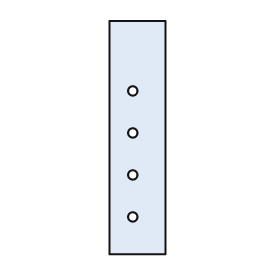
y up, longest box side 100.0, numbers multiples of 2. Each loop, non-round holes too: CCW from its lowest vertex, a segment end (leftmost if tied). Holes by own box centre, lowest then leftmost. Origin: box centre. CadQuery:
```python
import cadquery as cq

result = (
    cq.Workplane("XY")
    .moveTo(-12.0, -50.0)
    .lineTo(12.0, -50.0)
    .lineTo(12.0, 50.0)
    .lineTo(-12.0, 50.0)
    .close()
    .moveTo(-2.0, -34.0)
    .circle(2.0)
    .moveTo(-2.0, -16.0)
    .circle(2.0)
    .moveTo(-2.0, 2.0)
    .circle(2.0)
    .moveTo(-2.0, 20.0)
    .circle(2.0)
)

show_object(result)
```